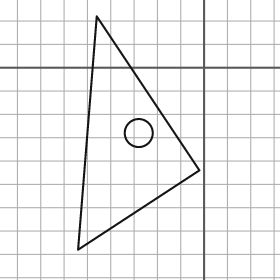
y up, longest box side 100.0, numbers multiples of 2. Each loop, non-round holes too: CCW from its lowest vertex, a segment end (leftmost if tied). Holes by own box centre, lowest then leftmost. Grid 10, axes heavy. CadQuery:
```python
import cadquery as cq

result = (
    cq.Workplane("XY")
    .moveTo(-54.0, -78.0)
    .lineTo(-2.0, -44.0)
    .lineTo(-46.0, 22.0)
    .close()
    .moveTo(-28.0, -28.0)
    .circle(6.0)
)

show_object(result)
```